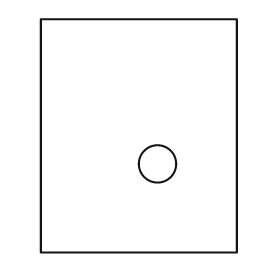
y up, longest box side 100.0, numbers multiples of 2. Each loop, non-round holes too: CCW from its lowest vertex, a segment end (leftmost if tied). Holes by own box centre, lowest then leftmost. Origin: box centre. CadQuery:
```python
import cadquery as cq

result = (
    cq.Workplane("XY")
    .moveTo(-42.0, -50.0)
    .lineTo(42.0, -50.0)
    .lineTo(42.0, 50.0)
    .lineTo(-42.0, 50.0)
    .close()
    .moveTo(8.0, -12.0)
    .circle(8.0)
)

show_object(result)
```